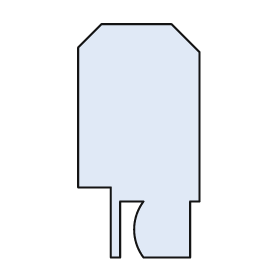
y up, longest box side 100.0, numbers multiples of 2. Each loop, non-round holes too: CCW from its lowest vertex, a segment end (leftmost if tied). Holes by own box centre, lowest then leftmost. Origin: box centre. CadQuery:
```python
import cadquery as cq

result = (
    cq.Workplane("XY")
    .moveTo(-12.0, -50.0)
    .lineTo(-8.0, -50.0)
    .lineTo(-8.0, -26.0)
    .lineTo(2.0, -26.0)
    .threePointArc((-2.0, -38.0), (2.0, -50.0))
    .lineTo(22.0, -50.0)
    .lineTo(22.0, -26.0)
    .lineTo(26.0, -26.0)
    .lineTo(26.0, 38.0)
    .lineTo(14.0, 50.0)
    .lineTo(-16.0, 50.0)
    .lineTo(-26.0, 40.0)
    .lineTo(-26.0, -20.0)
    .lineTo(-12.0, -20.0)
    .close()
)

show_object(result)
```